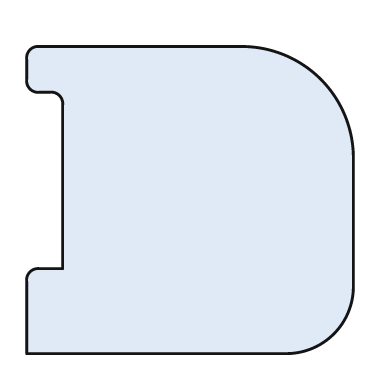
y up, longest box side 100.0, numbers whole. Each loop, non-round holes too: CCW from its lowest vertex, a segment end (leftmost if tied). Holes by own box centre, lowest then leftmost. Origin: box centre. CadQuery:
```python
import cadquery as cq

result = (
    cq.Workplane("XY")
    .moveTo(-50.0, -47.0)
    .lineTo(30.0, -47.0)
    .threePointArc((44.0, -41.0), (50.0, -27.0))
    .lineTo(50.0, 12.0)
    .threePointArc((40.0, 37.0), (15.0, 47.0))
    .lineTo(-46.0, 47.0)
    .threePointArc((-49.0, 46.0), (-50.0, 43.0))
    .lineTo(-50.0, 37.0)
    .threePointArc((-49.0, 34.0), (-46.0, 33.0))
    .lineTo(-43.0, 33.0)
    .threePointArc((-40.0, 32.0), (-39.0, 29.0))
    .lineTo(-39.0, -21.0)
    .lineTo(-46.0, -21.0)
    .threePointArc((-49.0, -22.0), (-50.0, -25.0))
    .close()
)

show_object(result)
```